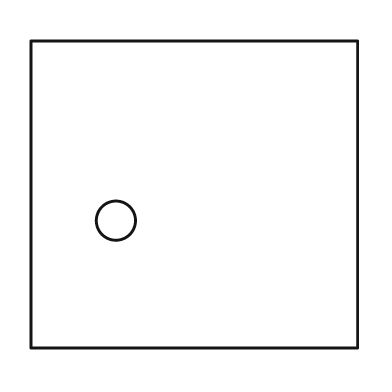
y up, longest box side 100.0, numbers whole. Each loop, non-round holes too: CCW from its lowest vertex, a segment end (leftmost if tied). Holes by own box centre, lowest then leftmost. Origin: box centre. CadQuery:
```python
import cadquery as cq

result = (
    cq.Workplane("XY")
    .moveTo(-50.0, -47.0)
    .lineTo(50.0, -47.0)
    .lineTo(50.0, 47.0)
    .lineTo(-50.0, 47.0)
    .close()
    .moveTo(-24.0, -8.0)
    .circle(6.0)
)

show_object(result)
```